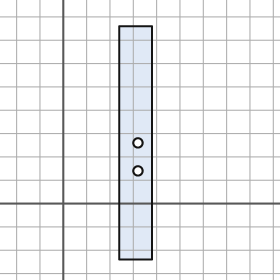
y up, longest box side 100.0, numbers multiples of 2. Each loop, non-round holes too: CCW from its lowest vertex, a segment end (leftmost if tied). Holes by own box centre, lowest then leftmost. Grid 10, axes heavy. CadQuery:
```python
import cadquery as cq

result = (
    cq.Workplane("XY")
    .moveTo(24.0, -24.0)
    .lineTo(38.0, -24.0)
    .lineTo(38.0, 76.0)
    .lineTo(24.0, 76.0)
    .close()
    .moveTo(32.0, 14.0)
    .circle(2.0)
    .moveTo(32.0, 26.0)
    .circle(2.0)
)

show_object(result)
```